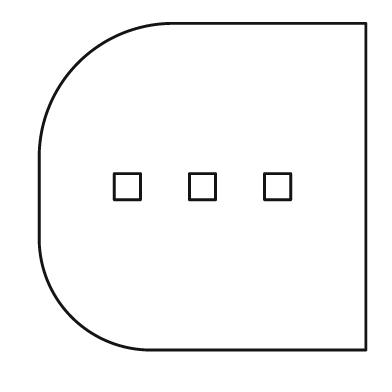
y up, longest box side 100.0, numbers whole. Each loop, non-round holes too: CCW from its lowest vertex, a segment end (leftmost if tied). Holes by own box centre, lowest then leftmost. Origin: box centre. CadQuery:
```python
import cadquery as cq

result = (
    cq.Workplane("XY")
    .moveTo(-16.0, -50.0)
    .lineTo(50.0, -50.0)
    .lineTo(50.0, 50.0)
    .lineTo(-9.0, 50.0)
    .threePointArc((-38.0, 38.0), (-50.0, 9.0))
    .lineTo(-50.0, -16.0)
    .threePointArc((-40.0, -40.0), (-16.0, -50.0))
    .close()
    .moveTo(-27.0, -4.0)
    .lineTo(-19.0, -4.0)
    .lineTo(-19.0, 4.0)
    .lineTo(-27.0, 4.0)
    .close()
    .moveTo(-4.0, -4.0)
    .lineTo(4.0, -4.0)
    .lineTo(4.0, 4.0)
    .lineTo(-4.0, 4.0)
    .close()
    .moveTo(19.0, -4.0)
    .lineTo(27.0, -4.0)
    .lineTo(27.0, 4.0)
    .lineTo(19.0, 4.0)
    .close()
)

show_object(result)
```